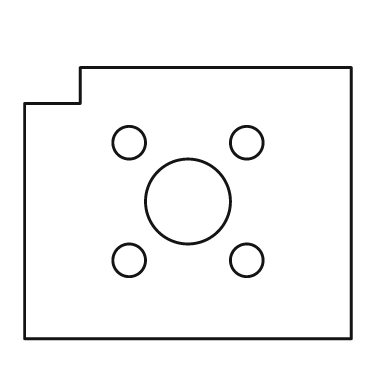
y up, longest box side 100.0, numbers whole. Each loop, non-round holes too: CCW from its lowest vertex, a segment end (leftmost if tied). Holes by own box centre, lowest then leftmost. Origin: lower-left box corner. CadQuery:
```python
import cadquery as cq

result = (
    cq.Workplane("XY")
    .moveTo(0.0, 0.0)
    .lineTo(100.0, 0.0)
    .lineTo(100.0, 83.0)
    .lineTo(17.0, 83.0)
    .lineTo(17.0, 72.0)
    .lineTo(0.0, 72.0)
    .close()
    .moveTo(32.0, 24.0)
    .circle(5.0)
    .moveTo(68.0, 24.0)
    .circle(5.0)
    .moveTo(50.0, 42.0)
    .circle(13.0)
    .moveTo(32.0, 60.0)
    .circle(5.0)
    .moveTo(68.0, 60.0)
    .circle(5.0)
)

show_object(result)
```